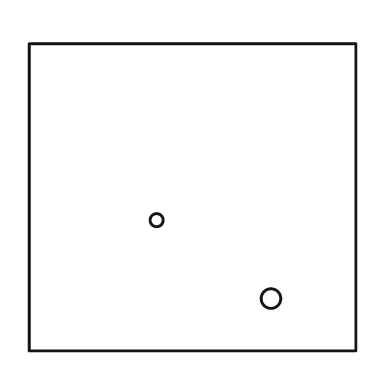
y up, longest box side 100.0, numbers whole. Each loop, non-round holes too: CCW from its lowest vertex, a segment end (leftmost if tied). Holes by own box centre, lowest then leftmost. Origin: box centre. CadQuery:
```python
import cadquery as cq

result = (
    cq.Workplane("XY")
    .moveTo(-50.0, -47.0)
    .lineTo(50.0, -47.0)
    .lineTo(50.0, 47.0)
    .lineTo(-50.0, 47.0)
    .close()
    .moveTo(24.0, -31.0)
    .circle(3.0)
    .moveTo(-11.0, -7.0)
    .circle(2.0)
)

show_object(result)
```